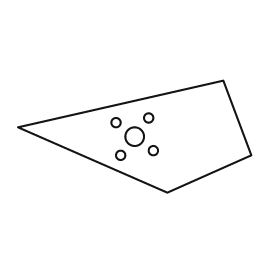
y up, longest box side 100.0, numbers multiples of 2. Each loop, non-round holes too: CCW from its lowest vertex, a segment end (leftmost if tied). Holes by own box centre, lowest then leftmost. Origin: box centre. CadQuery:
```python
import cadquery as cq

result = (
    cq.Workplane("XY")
    .moveTo(14.0, -24.0)
    .lineTo(50.0, -8.0)
    .lineTo(38.0, 24.0)
    .lineTo(-50.0, 4.0)
    .close()
    .moveTo(-6.0, -8.0)
    .circle(2.0)
    .moveTo(8.0, -6.0)
    .circle(2.0)
    .moveTo(0.0, 0.0)
    .circle(4.0)
    .moveTo(-8.0, 6.0)
    .circle(2.0)
    .moveTo(6.0, 8.0)
    .circle(2.0)
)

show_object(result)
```